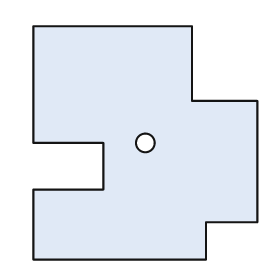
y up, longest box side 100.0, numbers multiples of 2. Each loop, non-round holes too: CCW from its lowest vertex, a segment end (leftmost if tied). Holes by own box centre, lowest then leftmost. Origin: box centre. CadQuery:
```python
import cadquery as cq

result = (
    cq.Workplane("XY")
    .moveTo(-48.0, -50.0)
    .lineTo(26.0, -50.0)
    .lineTo(26.0, -34.0)
    .lineTo(48.0, -34.0)
    .lineTo(48.0, 18.0)
    .lineTo(20.0, 18.0)
    .lineTo(20.0, 50.0)
    .lineTo(-48.0, 50.0)
    .lineTo(-48.0, 0.0)
    .lineTo(-18.0, 0.0)
    .lineTo(-18.0, -20.0)
    .lineTo(-48.0, -20.0)
    .close()
    .moveTo(0.0, 0.0)
    .circle(4.0)
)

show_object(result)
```